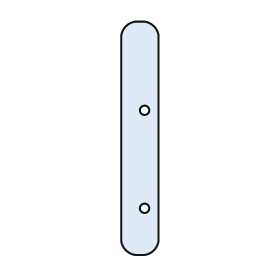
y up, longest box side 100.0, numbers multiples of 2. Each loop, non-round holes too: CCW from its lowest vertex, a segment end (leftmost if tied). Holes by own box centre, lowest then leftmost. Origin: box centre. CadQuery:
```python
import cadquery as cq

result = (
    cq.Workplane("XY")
    .moveTo(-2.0, -50.0)
    .lineTo(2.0, -50.0)
    .threePointArc((6.0, -48.0), (8.0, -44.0))
    .lineTo(8.0, 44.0)
    .threePointArc((6.0, 48.0), (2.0, 50.0))
    .lineTo(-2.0, 50.0)
    .threePointArc((-6.0, 48.0), (-8.0, 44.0))
    .lineTo(-8.0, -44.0)
    .threePointArc((-6.0, -48.0), (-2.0, -50.0))
    .close()
    .moveTo(2.0, -30.0)
    .circle(2.0)
    .moveTo(2.0, 12.0)
    .circle(2.0)
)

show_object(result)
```